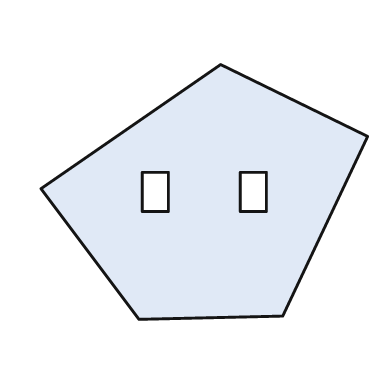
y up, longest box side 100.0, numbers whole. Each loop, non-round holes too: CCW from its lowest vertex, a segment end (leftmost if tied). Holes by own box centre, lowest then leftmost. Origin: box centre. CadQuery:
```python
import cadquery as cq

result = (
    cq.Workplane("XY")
    .moveTo(-20.0, -39.0)
    .lineTo(24.0, -38.0)
    .lineTo(50.0, 17.0)
    .lineTo(5.0, 39.0)
    .lineTo(-50.0, 1.0)
    .close()
    .moveTo(-19.0, -6.0)
    .lineTo(-11.0, -6.0)
    .lineTo(-11.0, 6.0)
    .lineTo(-19.0, 6.0)
    .close()
    .moveTo(11.0, -6.0)
    .lineTo(19.0, -6.0)
    .lineTo(19.0, 6.0)
    .lineTo(11.0, 6.0)
    .close()
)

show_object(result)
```